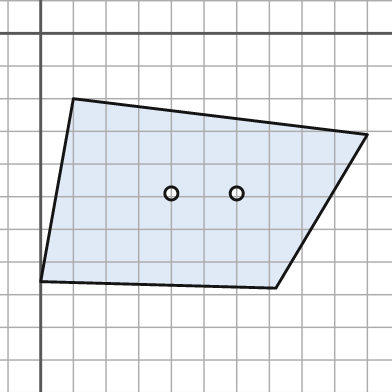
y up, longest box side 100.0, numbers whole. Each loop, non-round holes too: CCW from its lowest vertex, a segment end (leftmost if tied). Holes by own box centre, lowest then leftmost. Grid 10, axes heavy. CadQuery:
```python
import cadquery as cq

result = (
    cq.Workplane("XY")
    .moveTo(72.0, -78.0)
    .lineTo(100.0, -31.0)
    .lineTo(10.0, -20.0)
    .lineTo(0.0, -76.0)
    .close()
    .moveTo(40.0, -49.0)
    .circle(2.0)
    .moveTo(60.0, -49.0)
    .circle(2.0)
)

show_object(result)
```